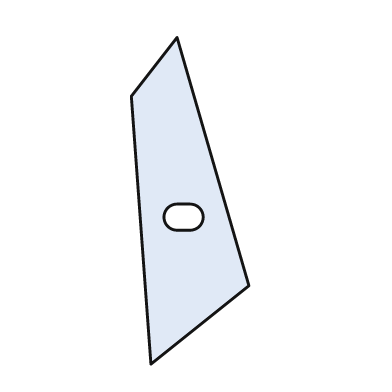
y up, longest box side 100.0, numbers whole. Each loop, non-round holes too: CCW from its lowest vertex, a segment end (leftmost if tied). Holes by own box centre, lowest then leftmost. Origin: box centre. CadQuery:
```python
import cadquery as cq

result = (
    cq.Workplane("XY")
    .moveTo(-12.0, -50.0)
    .lineTo(18.0, -26.0)
    .lineTo(-4.0, 50.0)
    .lineTo(-18.0, 32.0)
    .close()
    .moveTo(-4.0, -9.0)
    .lineTo(0.0, -9.0)
    .threePointArc((4.0, -5.0), (0.0, -1.0))
    .lineTo(-4.0, -1.0)
    .threePointArc((-8.0, -5.0), (-4.0, -9.0))
    .close()
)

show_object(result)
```